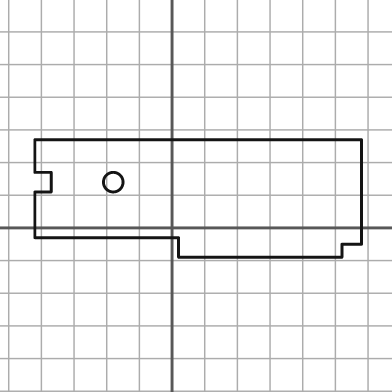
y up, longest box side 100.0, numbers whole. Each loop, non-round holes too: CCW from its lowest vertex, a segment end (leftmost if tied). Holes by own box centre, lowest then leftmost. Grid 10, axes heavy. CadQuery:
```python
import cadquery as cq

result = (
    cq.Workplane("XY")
    .moveTo(2.0, -9.0)
    .lineTo(52.0, -9.0)
    .lineTo(52.0, -5.0)
    .lineTo(58.0, -5.0)
    .lineTo(58.0, 27.0)
    .lineTo(-42.0, 27.0)
    .lineTo(-42.0, 17.0)
    .lineTo(-37.0, 17.0)
    .lineTo(-37.0, 11.0)
    .lineTo(-42.0, 11.0)
    .lineTo(-42.0, -3.0)
    .lineTo(2.0, -3.0)
    .close()
    .moveTo(-18.0, 14.0)
    .circle(3.0)
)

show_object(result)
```